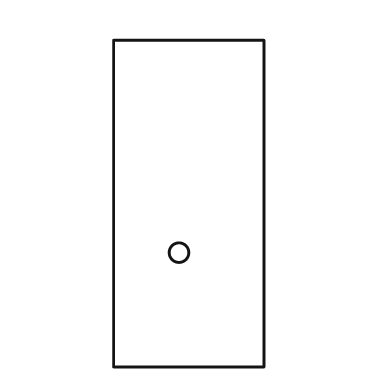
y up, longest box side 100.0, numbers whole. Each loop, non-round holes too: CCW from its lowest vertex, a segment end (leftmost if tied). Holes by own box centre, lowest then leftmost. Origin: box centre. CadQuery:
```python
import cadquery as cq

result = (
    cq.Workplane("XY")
    .moveTo(-23.0, -50.0)
    .lineTo(23.0, -50.0)
    .lineTo(23.0, 50.0)
    .lineTo(-23.0, 50.0)
    .close()
    .moveTo(-3.0, -15.0)
    .circle(3.0)
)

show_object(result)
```